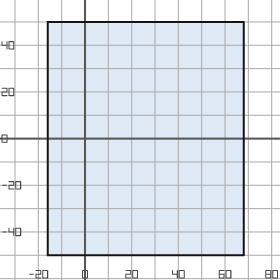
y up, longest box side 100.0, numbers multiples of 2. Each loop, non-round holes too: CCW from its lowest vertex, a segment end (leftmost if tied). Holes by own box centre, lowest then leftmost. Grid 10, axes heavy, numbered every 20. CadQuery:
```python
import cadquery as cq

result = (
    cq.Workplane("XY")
    .moveTo(-16.0, -50.0)
    .lineTo(68.0, -50.0)
    .lineTo(68.0, 50.0)
    .lineTo(-16.0, 50.0)
    .close()
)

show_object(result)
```